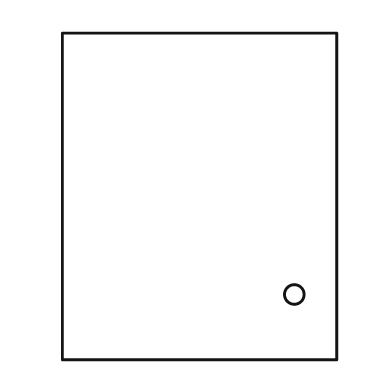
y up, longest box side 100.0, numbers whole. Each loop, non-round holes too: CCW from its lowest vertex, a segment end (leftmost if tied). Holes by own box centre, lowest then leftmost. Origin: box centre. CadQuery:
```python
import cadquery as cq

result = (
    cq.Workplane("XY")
    .moveTo(-42.0, -50.0)
    .lineTo(42.0, -50.0)
    .lineTo(42.0, 50.0)
    .lineTo(-42.0, 50.0)
    .close()
    .moveTo(29.0, -30.0)
    .circle(3.0)
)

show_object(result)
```